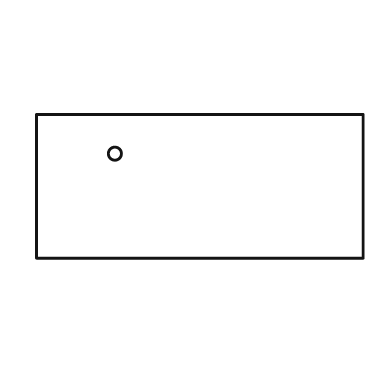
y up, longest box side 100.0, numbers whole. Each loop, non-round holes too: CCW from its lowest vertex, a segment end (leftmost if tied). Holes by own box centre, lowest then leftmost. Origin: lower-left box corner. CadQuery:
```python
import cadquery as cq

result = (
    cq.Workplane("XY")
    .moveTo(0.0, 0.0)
    .lineTo(100.0, 0.0)
    .lineTo(100.0, 44.0)
    .lineTo(0.0, 44.0)
    .close()
    .moveTo(24.0, 32.0)
    .circle(2.0)
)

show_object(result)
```